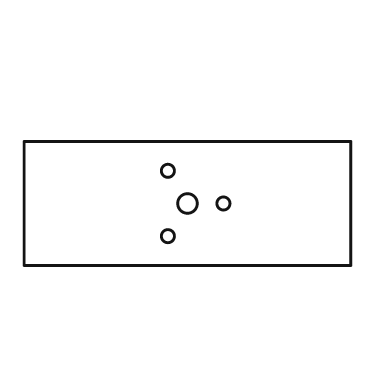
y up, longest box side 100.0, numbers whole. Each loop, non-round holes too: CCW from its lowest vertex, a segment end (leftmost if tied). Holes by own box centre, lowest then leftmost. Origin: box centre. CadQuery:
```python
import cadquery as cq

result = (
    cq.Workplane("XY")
    .moveTo(-50.0, -19.0)
    .lineTo(50.0, -19.0)
    .lineTo(50.0, 19.0)
    .lineTo(-50.0, 19.0)
    .close()
    .moveTo(-6.0, -10.0)
    .circle(2.0)
    .moveTo(0.0, 0.0)
    .circle(3.0)
    .moveTo(11.0, 0.0)
    .circle(2.0)
    .moveTo(-6.0, 10.0)
    .circle(2.0)
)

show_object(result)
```